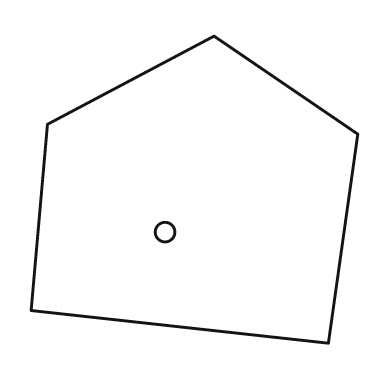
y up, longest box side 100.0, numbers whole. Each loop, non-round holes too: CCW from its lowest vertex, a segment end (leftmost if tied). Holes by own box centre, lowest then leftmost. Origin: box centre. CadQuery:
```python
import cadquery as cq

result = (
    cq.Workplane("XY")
    .moveTo(41.0, -47.0)
    .lineTo(50.0, 17.0)
    .lineTo(6.0, 47.0)
    .lineTo(-45.0, 20.0)
    .lineTo(-50.0, -37.0)
    .close()
    .moveTo(-9.0, -13.0)
    .circle(3.0)
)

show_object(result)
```